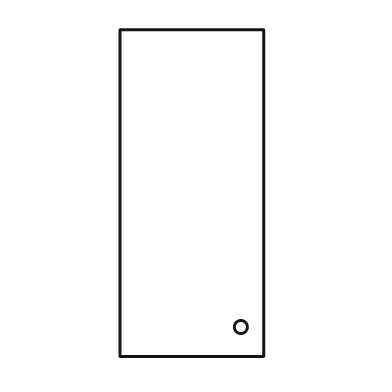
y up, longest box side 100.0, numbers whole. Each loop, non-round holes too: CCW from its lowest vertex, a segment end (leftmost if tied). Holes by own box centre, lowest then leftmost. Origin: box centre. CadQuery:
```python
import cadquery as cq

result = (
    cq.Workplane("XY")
    .moveTo(-22.0, -50.0)
    .lineTo(22.0, -50.0)
    .lineTo(22.0, 50.0)
    .lineTo(-22.0, 50.0)
    .close()
    .moveTo(15.0, -41.0)
    .circle(2.0)
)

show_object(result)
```